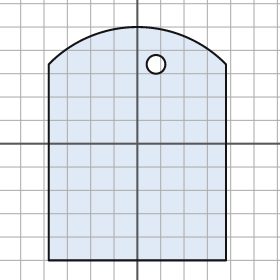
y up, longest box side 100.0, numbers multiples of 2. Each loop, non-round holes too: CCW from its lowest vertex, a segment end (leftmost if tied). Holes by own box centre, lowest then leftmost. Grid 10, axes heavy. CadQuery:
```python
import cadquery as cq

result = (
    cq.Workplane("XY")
    .moveTo(-38.0, -50.0)
    .lineTo(38.0, -50.0)
    .lineTo(38.0, 34.0)
    .threePointArc((0.0, 50.0), (-38.0, 34.0))
    .close()
    .moveTo(8.0, 34.0)
    .circle(4.0)
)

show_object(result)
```